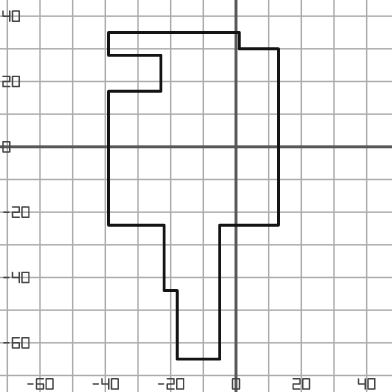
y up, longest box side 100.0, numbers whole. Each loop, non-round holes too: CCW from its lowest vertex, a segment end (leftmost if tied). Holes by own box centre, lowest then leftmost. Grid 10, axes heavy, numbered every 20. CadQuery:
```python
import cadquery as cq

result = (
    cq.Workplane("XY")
    .moveTo(-18.0, -65.0)
    .lineTo(-5.0, -65.0)
    .lineTo(-5.0, -24.0)
    .lineTo(13.0, -24.0)
    .lineTo(13.0, 30.0)
    .lineTo(1.0, 30.0)
    .lineTo(1.0, 35.0)
    .lineTo(-39.0, 35.0)
    .lineTo(-39.0, 28.0)
    .lineTo(-23.0, 28.0)
    .lineTo(-23.0, 17.0)
    .lineTo(-39.0, 17.0)
    .lineTo(-39.0, -24.0)
    .lineTo(-22.0, -24.0)
    .lineTo(-22.0, -44.0)
    .lineTo(-18.0, -44.0)
    .close()
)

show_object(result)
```